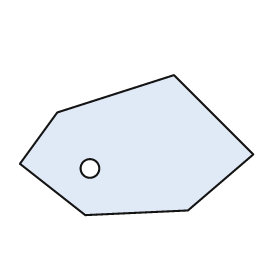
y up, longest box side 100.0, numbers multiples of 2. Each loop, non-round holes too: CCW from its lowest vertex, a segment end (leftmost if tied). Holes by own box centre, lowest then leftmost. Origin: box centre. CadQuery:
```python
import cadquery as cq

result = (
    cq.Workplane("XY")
    .moveTo(-22.0, -30.0)
    .lineTo(22.0, -28.0)
    .lineTo(50.0, -4.0)
    .lineTo(16.0, 30.0)
    .lineTo(-34.0, 14.0)
    .lineTo(-50.0, -8.0)
    .close()
    .moveTo(-20.0, -10.0)
    .circle(4.0)
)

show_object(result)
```